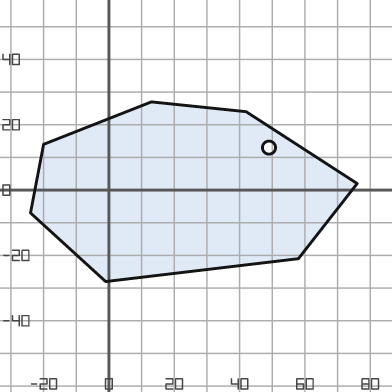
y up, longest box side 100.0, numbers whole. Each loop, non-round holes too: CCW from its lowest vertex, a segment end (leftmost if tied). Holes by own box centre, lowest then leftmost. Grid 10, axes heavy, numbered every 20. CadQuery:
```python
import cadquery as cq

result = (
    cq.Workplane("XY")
    .moveTo(-1.0, -28.0)
    .lineTo(58.0, -21.0)
    .lineTo(76.0, 2.0)
    .lineTo(42.0, 24.0)
    .lineTo(13.0, 27.0)
    .lineTo(-20.0, 14.0)
    .lineTo(-24.0, -7.0)
    .close()
    .moveTo(49.0, 13.0)
    .circle(2.0)
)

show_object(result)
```